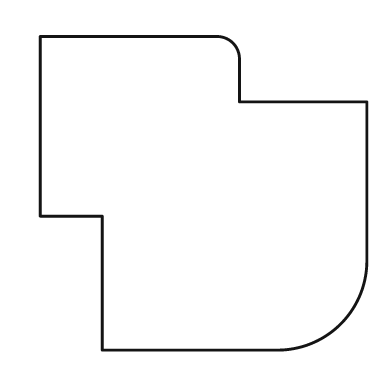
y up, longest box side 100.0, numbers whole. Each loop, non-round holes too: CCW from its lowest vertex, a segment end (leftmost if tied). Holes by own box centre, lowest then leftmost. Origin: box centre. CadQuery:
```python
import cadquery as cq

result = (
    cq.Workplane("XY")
    .moveTo(-31.0, -48.0)
    .lineTo(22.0, -48.0)
    .threePointArc((42.0, -40.0), (50.0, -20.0))
    .lineTo(50.0, 28.0)
    .lineTo(11.0, 28.0)
    .lineTo(11.0, 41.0)
    .threePointArc((9.0, 46.0), (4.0, 48.0))
    .lineTo(-50.0, 48.0)
    .lineTo(-50.0, -7.0)
    .lineTo(-31.0, -7.0)
    .close()
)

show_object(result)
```